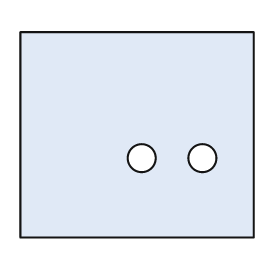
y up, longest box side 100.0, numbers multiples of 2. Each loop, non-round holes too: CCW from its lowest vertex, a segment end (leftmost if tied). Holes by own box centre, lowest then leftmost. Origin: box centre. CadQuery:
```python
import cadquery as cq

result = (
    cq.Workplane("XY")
    .moveTo(-50.0, -44.0)
    .lineTo(50.0, -44.0)
    .lineTo(50.0, 44.0)
    .lineTo(-50.0, 44.0)
    .close()
    .moveTo(2.0, -10.0)
    .circle(6.0)
    .moveTo(28.0, -10.0)
    .circle(6.0)
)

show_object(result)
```